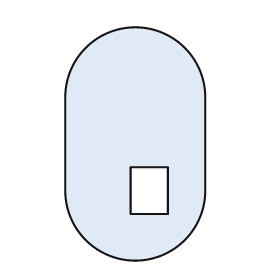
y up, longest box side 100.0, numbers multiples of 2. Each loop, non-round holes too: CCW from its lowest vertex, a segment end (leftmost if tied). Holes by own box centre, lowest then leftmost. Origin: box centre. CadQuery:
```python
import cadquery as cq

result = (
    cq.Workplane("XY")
    .moveTo(-30.0, -20.0)
    .threePointArc((0.0, -50.0), (30.0, -20.0))
    .lineTo(30.0, 20.0)
    .threePointArc((0.0, 50.0), (-30.0, 20.0))
    .close()
    .moveTo(-2.0, -30.0)
    .lineTo(14.0, -30.0)
    .lineTo(14.0, -10.0)
    .lineTo(-2.0, -10.0)
    .close()
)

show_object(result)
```